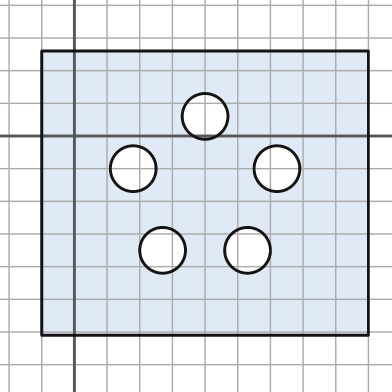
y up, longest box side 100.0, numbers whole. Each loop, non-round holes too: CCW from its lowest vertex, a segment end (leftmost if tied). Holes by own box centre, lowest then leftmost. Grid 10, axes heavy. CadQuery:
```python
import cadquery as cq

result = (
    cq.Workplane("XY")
    .moveTo(-10.0, -61.0)
    .lineTo(90.0, -61.0)
    .lineTo(90.0, 26.0)
    .lineTo(-10.0, 26.0)
    .close()
    .moveTo(27.0, -35.0)
    .circle(7.0)
    .moveTo(53.0, -35.0)
    .circle(7.0)
    .moveTo(18.0, -10.0)
    .circle(7.0)
    .moveTo(62.0, -10.0)
    .circle(7.0)
    .moveTo(40.0, 6.0)
    .circle(7.0)
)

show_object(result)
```